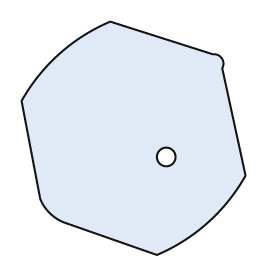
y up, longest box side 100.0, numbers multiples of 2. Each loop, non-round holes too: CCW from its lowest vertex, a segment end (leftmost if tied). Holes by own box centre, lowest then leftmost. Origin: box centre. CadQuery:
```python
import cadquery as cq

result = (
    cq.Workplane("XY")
    .moveTo(10.0, -50.0)
    .threePointArc((32.0, -36.0), (48.0, -16.0))
    .lineTo(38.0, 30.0)
    .threePointArc((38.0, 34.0), (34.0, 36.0))
    .lineTo(-10.0, 50.0)
    .threePointArc((-32.0, 36.0), (-48.0, 16.0))
    .lineTo(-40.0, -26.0)
    .threePointArc((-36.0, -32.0), (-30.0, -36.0))
    .close()
    .moveTo(14.0, -8.0)
    .circle(4.0)
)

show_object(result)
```